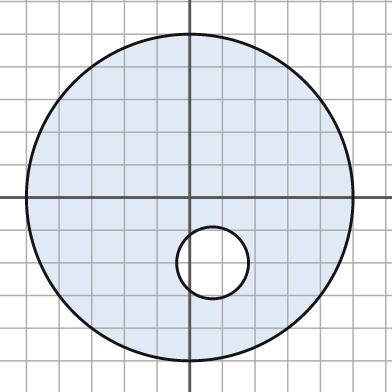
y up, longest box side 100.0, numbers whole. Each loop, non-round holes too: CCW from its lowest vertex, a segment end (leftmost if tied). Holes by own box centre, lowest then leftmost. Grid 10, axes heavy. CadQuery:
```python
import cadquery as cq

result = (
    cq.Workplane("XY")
    .moveTo(0.0, 0.0)
    .circle(50.0)
    .moveTo(7.0, -20.0)
    .circle(11.0)
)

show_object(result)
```